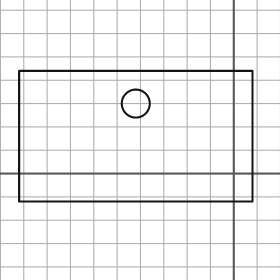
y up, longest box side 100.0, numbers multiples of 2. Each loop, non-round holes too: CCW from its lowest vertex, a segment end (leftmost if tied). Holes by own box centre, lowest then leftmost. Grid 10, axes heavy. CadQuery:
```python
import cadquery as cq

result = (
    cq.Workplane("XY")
    .moveTo(-92.0, -12.0)
    .lineTo(8.0, -12.0)
    .lineTo(8.0, 44.0)
    .lineTo(-92.0, 44.0)
    .close()
    .moveTo(-42.0, 30.0)
    .circle(6.0)
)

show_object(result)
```